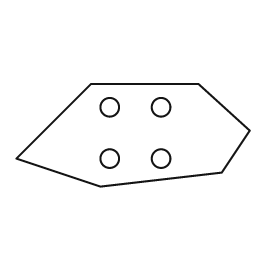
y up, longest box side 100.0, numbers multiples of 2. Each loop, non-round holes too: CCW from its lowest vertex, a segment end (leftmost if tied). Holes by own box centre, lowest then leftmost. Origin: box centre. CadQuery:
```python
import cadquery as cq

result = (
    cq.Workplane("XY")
    .moveTo(-14.0, -22.0)
    .lineTo(38.0, -16.0)
    .lineTo(50.0, 2.0)
    .lineTo(28.0, 22.0)
    .lineTo(-18.0, 22.0)
    .lineTo(-50.0, -10.0)
    .close()
    .moveTo(-10.0, -10.0)
    .circle(4.0)
    .moveTo(12.0, -10.0)
    .circle(4.0)
    .moveTo(-10.0, 12.0)
    .circle(4.0)
    .moveTo(12.0, 12.0)
    .circle(4.0)
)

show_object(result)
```